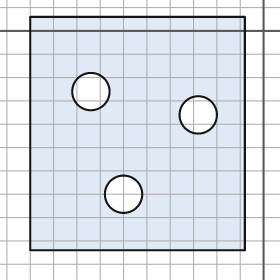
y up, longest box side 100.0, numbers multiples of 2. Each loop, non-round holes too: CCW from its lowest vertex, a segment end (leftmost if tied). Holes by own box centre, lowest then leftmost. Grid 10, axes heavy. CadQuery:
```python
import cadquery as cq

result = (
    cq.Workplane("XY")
    .moveTo(-100.0, -94.0)
    .lineTo(-8.0, -94.0)
    .lineTo(-8.0, 6.0)
    .lineTo(-100.0, 6.0)
    .close()
    .moveTo(-60.0, -70.0)
    .circle(8.0)
    .moveTo(-28.0, -36.0)
    .circle(8.0)
    .moveTo(-74.0, -26.0)
    .circle(8.0)
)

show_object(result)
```